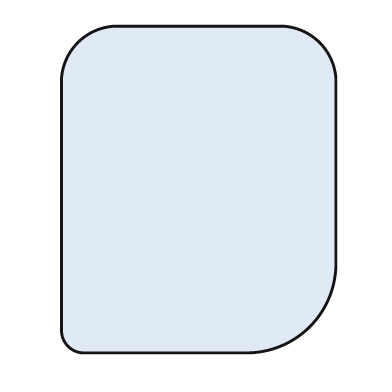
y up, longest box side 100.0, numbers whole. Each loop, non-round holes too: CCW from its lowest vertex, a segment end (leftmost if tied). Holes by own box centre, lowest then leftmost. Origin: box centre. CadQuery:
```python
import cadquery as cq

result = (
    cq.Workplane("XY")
    .moveTo(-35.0, -50.0)
    .lineTo(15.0, -50.0)
    .threePointArc((34.0, -42.0), (42.0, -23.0))
    .lineTo(42.0, 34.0)
    .threePointArc((37.0, 45.0), (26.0, 50.0))
    .lineTo(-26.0, 50.0)
    .threePointArc((-37.0, 45.0), (-42.0, 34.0))
    .lineTo(-42.0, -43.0)
    .threePointArc((-40.0, -48.0), (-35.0, -50.0))
    .close()
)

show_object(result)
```